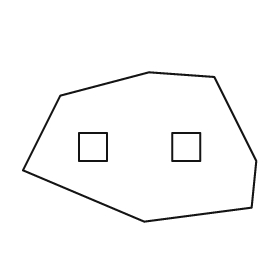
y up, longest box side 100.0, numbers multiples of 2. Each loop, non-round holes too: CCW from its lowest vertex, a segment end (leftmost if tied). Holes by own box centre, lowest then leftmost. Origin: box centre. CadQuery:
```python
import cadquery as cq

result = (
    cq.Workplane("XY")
    .moveTo(2.0, -32.0)
    .lineTo(48.0, -26.0)
    .lineTo(50.0, -6.0)
    .lineTo(32.0, 30.0)
    .lineTo(4.0, 32.0)
    .lineTo(-34.0, 22.0)
    .lineTo(-50.0, -10.0)
    .close()
    .moveTo(-26.0, -6.0)
    .lineTo(-14.0, -6.0)
    .lineTo(-14.0, 6.0)
    .lineTo(-26.0, 6.0)
    .close()
    .moveTo(14.0, -6.0)
    .lineTo(26.0, -6.0)
    .lineTo(26.0, 6.0)
    .lineTo(14.0, 6.0)
    .close()
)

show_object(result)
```